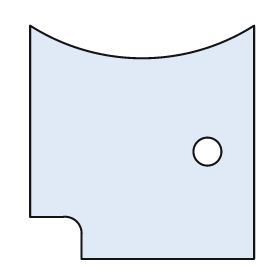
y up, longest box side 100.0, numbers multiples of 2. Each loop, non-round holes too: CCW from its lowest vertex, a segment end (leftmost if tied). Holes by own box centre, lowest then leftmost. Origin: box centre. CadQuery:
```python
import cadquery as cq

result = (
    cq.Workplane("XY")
    .moveTo(-26.0, -50.0)
    .lineTo(48.0, -50.0)
    .lineTo(48.0, 50.0)
    .threePointArc((0.0, 36.0), (-48.0, 50.0))
    .lineTo(-48.0, -32.0)
    .lineTo(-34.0, -32.0)
    .threePointArc((-28.0, -34.0), (-26.0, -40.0))
    .close()
    .moveTo(28.0, -4.0)
    .circle(6.0)
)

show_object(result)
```